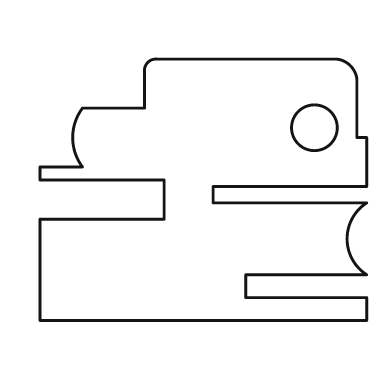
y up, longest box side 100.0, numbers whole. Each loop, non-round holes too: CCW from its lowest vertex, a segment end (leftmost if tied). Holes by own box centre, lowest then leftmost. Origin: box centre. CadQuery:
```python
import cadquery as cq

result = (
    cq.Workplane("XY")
    .moveTo(-50.0, -40.0)
    .lineTo(50.0, -40.0)
    .lineTo(50.0, -33.0)
    .lineTo(13.0, -33.0)
    .lineTo(13.0, -26.0)
    .lineTo(50.0, -26.0)
    .threePointArc((44.0, -15.0), (50.0, -4.0))
    .lineTo(3.0, -4.0)
    .lineTo(3.0, 1.0)
    .lineTo(50.0, 1.0)
    .lineTo(50.0, 16.0)
    .lineTo(47.0, 16.0)
    .lineTo(47.0, 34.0)
    .threePointArc((45.0, 38.0), (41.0, 40.0))
    .lineTo(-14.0, 40.0)
    .threePointArc((-17.0, 39.0), (-18.0, 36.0))
    .lineTo(-18.0, 25.0)
    .lineTo(-37.0, 25.0)
    .threePointArc((-40.0, 16.0), (-37.0, 7.0))
    .lineTo(-50.0, 7.0)
    .lineTo(-50.0, 3.0)
    .lineTo(-12.0, 3.0)
    .lineTo(-12.0, -9.0)
    .lineTo(-50.0, -9.0)
    .close()
    .moveTo(34.0, 19.0)
    .circle(7.0)
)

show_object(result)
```